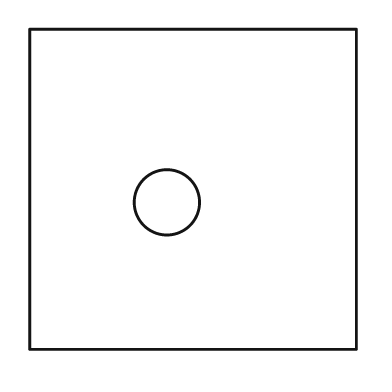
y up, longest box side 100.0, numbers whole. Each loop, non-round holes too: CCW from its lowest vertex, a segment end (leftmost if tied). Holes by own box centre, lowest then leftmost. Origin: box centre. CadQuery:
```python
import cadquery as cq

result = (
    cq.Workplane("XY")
    .moveTo(-50.0, -49.0)
    .lineTo(50.0, -49.0)
    .lineTo(50.0, 49.0)
    .lineTo(-50.0, 49.0)
    .close()
    .moveTo(-8.0, -4.0)
    .circle(10.0)
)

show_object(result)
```